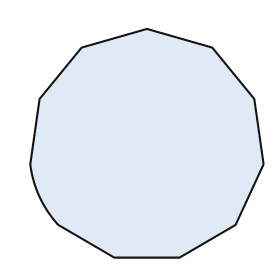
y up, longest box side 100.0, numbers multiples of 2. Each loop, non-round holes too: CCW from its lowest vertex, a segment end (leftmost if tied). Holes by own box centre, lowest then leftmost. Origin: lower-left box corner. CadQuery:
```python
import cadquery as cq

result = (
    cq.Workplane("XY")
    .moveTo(36.0, 0.0)
    .lineTo(64.0, 0.0)
    .lineTo(88.0, 14.0)
    .lineTo(100.0, 40.0)
    .lineTo(96.0, 68.0)
    .lineTo(78.0, 90.0)
    .lineTo(50.0, 98.0)
    .lineTo(22.0, 90.0)
    .lineTo(4.0, 68.0)
    .lineTo(0.0, 40.0)
    .threePointArc((4.0, 26.0), (12.0, 14.0))
    .close()
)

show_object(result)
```